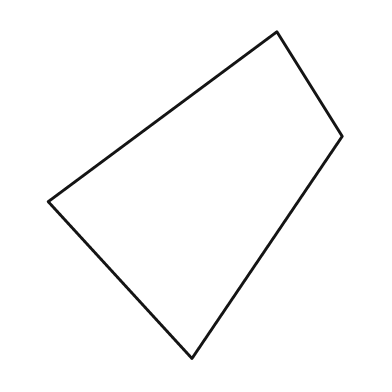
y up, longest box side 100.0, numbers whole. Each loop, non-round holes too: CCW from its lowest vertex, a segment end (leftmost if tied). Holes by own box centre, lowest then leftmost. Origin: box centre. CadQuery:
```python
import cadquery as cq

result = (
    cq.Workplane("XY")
    .moveTo(-1.0, -50.0)
    .lineTo(45.0, 18.0)
    .lineTo(25.0, 50.0)
    .lineTo(-45.0, -2.0)
    .close()
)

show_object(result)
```